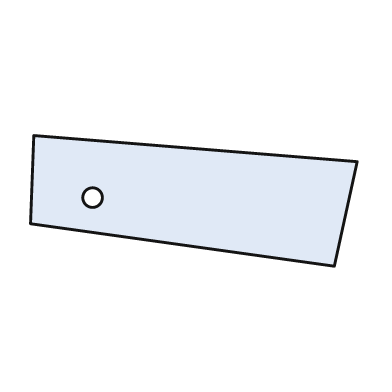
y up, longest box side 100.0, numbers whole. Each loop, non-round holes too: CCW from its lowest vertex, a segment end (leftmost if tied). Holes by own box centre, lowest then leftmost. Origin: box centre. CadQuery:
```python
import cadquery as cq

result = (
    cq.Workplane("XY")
    .moveTo(43.0, -20.0)
    .lineTo(50.0, 12.0)
    .lineTo(-49.0, 20.0)
    .lineTo(-50.0, -7.0)
    .close()
    .moveTo(-31.0, 1.0)
    .circle(3.0)
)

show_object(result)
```